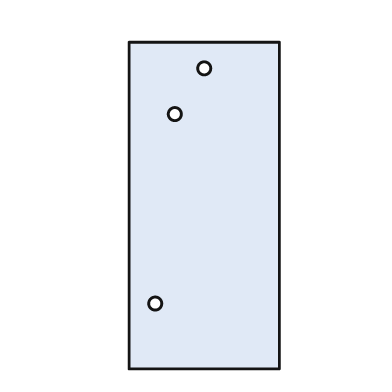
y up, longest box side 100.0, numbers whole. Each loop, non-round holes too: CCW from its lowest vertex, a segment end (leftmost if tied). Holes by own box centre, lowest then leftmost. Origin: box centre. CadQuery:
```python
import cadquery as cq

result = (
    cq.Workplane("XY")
    .moveTo(-23.0, -50.0)
    .lineTo(23.0, -50.0)
    .lineTo(23.0, 50.0)
    .lineTo(-23.0, 50.0)
    .close()
    .moveTo(-15.0, -30.0)
    .circle(2.0)
    .moveTo(-9.0, 28.0)
    .circle(2.0)
    .moveTo(0.0, 42.0)
    .circle(2.0)
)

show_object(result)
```